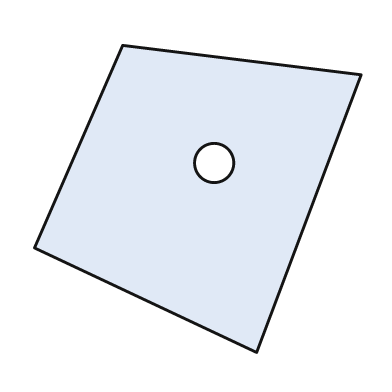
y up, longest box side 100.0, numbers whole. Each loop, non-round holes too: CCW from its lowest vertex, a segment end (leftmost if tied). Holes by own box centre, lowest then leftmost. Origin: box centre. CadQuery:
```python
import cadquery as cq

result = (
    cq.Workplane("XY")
    .moveTo(18.0, -47.0)
    .lineTo(50.0, 38.0)
    .lineTo(-23.0, 47.0)
    .lineTo(-50.0, -15.0)
    .close()
    .moveTo(5.0, 11.0)
    .circle(6.0)
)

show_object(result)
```